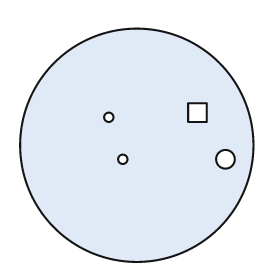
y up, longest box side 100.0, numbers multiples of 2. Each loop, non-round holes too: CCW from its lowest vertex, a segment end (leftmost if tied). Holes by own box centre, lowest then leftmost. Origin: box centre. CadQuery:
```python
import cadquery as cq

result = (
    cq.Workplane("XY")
    .moveTo(0.0, 0.0)
    .circle(50.0)
    .moveTo(-6.0, -6.0)
    .circle(2.0)
    .moveTo(38.0, -6.0)
    .circle(4.0)
    .moveTo(-12.0, 12.0)
    .circle(2.0)
    .moveTo(22.0, 10.0)
    .lineTo(30.0, 10.0)
    .lineTo(30.0, 18.0)
    .lineTo(22.0, 18.0)
    .close()
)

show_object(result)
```